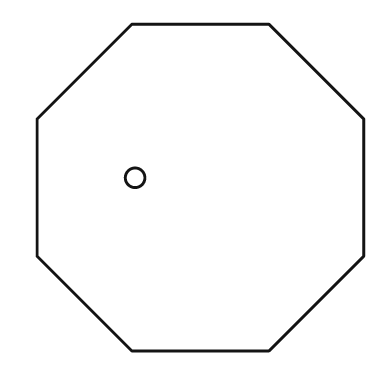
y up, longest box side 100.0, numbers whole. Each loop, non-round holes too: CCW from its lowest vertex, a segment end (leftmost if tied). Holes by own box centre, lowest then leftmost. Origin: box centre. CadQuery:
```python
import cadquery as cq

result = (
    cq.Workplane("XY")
    .moveTo(-21.0, -50.0)
    .lineTo(21.0, -50.0)
    .lineTo(50.0, -21.0)
    .lineTo(50.0, 21.0)
    .lineTo(21.0, 50.0)
    .lineTo(-21.0, 50.0)
    .lineTo(-50.0, 21.0)
    .lineTo(-50.0, -21.0)
    .close()
    .moveTo(-20.0, 3.0)
    .circle(3.0)
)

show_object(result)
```